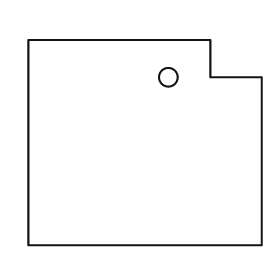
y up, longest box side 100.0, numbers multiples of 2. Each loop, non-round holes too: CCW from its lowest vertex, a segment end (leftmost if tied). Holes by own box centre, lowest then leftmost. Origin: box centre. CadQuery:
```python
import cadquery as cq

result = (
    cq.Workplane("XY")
    .moveTo(-50.0, -44.0)
    .lineTo(50.0, -44.0)
    .lineTo(50.0, 28.0)
    .lineTo(28.0, 28.0)
    .lineTo(28.0, 44.0)
    .lineTo(-50.0, 44.0)
    .close()
    .moveTo(10.0, 28.0)
    .circle(4.0)
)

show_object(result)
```